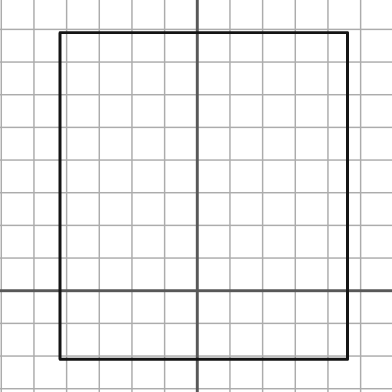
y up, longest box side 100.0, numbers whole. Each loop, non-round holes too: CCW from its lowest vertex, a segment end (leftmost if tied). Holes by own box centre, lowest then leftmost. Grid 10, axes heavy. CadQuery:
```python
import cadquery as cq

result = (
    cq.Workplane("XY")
    .moveTo(-42.0, -21.0)
    .lineTo(46.0, -21.0)
    .lineTo(46.0, 79.0)
    .lineTo(-42.0, 79.0)
    .close()
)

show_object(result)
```